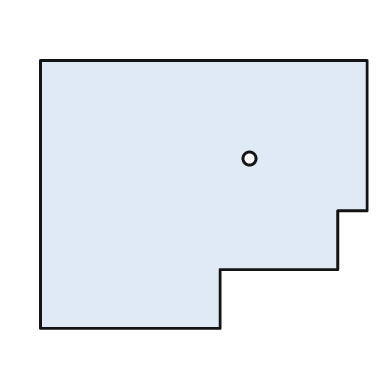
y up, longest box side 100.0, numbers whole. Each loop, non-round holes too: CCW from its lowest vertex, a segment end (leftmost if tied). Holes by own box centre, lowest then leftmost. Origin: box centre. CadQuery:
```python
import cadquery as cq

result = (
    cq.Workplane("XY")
    .moveTo(-50.0, -41.0)
    .lineTo(5.0, -41.0)
    .lineTo(5.0, -23.0)
    .lineTo(41.0, -23.0)
    .lineTo(41.0, -5.0)
    .lineTo(50.0, -5.0)
    .lineTo(50.0, 41.0)
    .lineTo(-50.0, 41.0)
    .close()
    .moveTo(14.0, 11.0)
    .circle(2.0)
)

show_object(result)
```